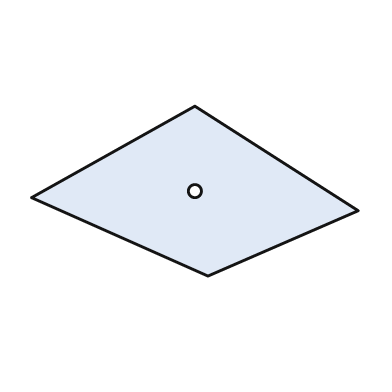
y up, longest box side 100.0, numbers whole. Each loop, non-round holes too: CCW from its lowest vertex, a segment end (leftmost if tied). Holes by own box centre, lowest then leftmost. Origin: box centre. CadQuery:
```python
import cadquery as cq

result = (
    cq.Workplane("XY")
    .moveTo(4.0, -26.0)
    .lineTo(50.0, -6.0)
    .lineTo(0.0, 26.0)
    .lineTo(-50.0, -2.0)
    .close()
    .moveTo(0.0, 0.0)
    .circle(2.0)
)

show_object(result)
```